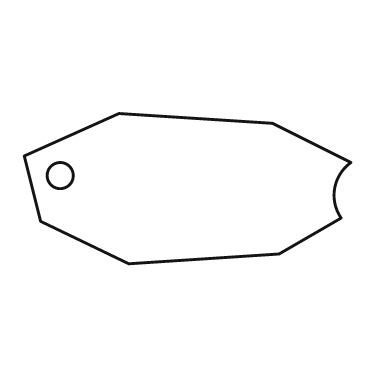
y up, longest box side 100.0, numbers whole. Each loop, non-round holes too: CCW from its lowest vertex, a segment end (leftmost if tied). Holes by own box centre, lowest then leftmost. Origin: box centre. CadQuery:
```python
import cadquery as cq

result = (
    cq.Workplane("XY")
    .moveTo(-18.0, -23.0)
    .lineTo(28.0, -20.0)
    .lineTo(47.0, -9.0)
    .threePointArc((45.0, 0.0), (50.0, 8.0))
    .lineTo(26.0, 20.0)
    .lineTo(-21.0, 23.0)
    .lineTo(-50.0, 10.0)
    .lineTo(-45.0, -10.0)
    .close()
    .moveTo(-39.0, 4.0)
    .circle(4.0)
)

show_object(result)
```